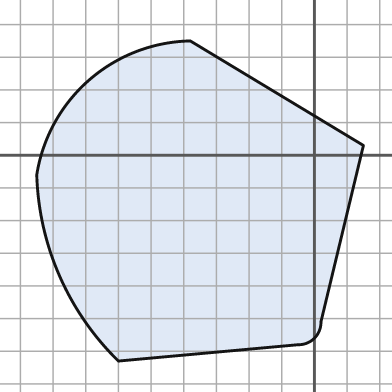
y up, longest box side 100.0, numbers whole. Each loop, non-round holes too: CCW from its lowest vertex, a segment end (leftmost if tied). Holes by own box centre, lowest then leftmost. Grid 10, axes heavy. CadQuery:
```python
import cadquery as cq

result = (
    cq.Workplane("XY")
    .moveTo(-60.0, -63.0)
    .lineTo(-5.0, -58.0)
    .threePointArc((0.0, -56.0), (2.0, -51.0))
    .lineTo(15.0, 3.0)
    .lineTo(-38.0, 35.0)
    .threePointArc((-69.0, 23.0), (-85.0, -6.0))
    .threePointArc((-78.0, -37.0), (-60.0, -63.0))
    .close()
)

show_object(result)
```